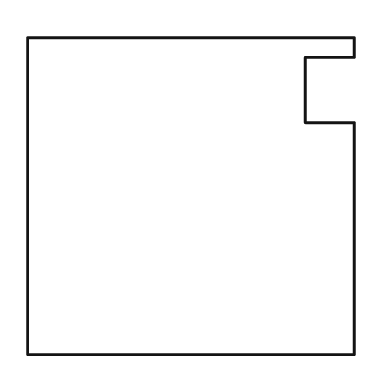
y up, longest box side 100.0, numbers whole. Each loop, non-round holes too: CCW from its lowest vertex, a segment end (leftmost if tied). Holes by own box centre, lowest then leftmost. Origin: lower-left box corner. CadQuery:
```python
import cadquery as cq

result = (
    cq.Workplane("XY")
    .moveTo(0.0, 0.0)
    .lineTo(100.0, 0.0)
    .lineTo(100.0, 71.0)
    .lineTo(85.0, 71.0)
    .lineTo(85.0, 91.0)
    .lineTo(100.0, 91.0)
    .lineTo(100.0, 97.0)
    .lineTo(0.0, 97.0)
    .close()
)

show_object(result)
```